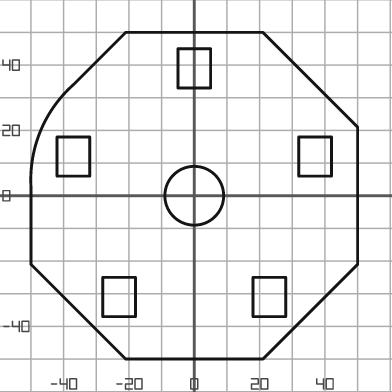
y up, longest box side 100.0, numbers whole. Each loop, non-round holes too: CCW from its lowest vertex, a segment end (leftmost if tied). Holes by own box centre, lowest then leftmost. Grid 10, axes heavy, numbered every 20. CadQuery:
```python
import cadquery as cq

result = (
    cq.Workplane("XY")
    .moveTo(-21.0, -50.0)
    .lineTo(21.0, -50.0)
    .lineTo(50.0, -21.0)
    .lineTo(50.0, 21.0)
    .lineTo(21.0, 50.0)
    .lineTo(-21.0, 50.0)
    .lineTo(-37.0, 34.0)
    .threePointArc((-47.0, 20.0), (-50.0, 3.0))
    .lineTo(-50.0, -21.0)
    .close()
    .moveTo(-28.0, -37.0)
    .lineTo(-18.0, -37.0)
    .lineTo(-18.0, -25.0)
    .lineTo(-28.0, -25.0)
    .close()
    .moveTo(18.0, -37.0)
    .lineTo(28.0, -37.0)
    .lineTo(28.0, -25.0)
    .lineTo(18.0, -25.0)
    .close()
    .moveTo(0.0, 0.0)
    .circle(9.0)
    .moveTo(-42.0, 6.0)
    .lineTo(-32.0, 6.0)
    .lineTo(-32.0, 18.0)
    .lineTo(-42.0, 18.0)
    .close()
    .moveTo(32.0, 6.0)
    .lineTo(42.0, 6.0)
    .lineTo(42.0, 18.0)
    .lineTo(32.0, 18.0)
    .close()
    .moveTo(-5.0, 33.0)
    .lineTo(5.0, 33.0)
    .lineTo(5.0, 45.0)
    .lineTo(-5.0, 45.0)
    .close()
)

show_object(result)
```